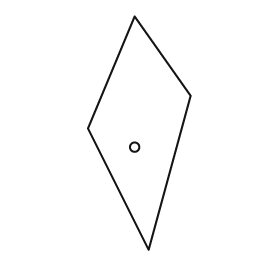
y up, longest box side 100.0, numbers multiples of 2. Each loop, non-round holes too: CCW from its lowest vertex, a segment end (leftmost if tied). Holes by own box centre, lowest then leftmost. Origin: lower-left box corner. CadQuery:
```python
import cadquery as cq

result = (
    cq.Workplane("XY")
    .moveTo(26.0, 0.0)
    .lineTo(44.0, 66.0)
    .lineTo(20.0, 100.0)
    .lineTo(0.0, 52.0)
    .close()
    .moveTo(20.0, 44.0)
    .circle(2.0)
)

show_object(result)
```